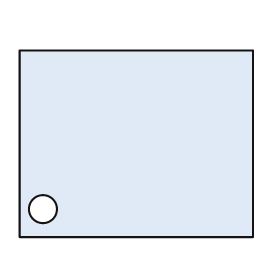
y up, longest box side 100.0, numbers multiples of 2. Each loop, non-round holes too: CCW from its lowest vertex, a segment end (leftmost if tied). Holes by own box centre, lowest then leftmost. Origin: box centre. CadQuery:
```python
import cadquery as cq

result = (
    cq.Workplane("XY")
    .moveTo(-50.0, -40.0)
    .lineTo(50.0, -40.0)
    .lineTo(50.0, 40.0)
    .lineTo(-50.0, 40.0)
    .close()
    .moveTo(-40.0, -28.0)
    .circle(6.0)
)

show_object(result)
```